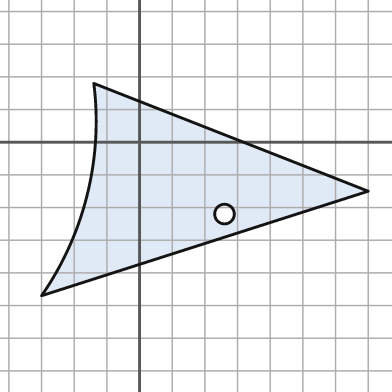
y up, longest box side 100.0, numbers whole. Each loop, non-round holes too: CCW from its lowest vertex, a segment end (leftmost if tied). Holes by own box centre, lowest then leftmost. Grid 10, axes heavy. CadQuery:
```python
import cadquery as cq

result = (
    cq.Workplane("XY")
    .moveTo(-30.0, -47.0)
    .lineTo(70.0, -15.0)
    .lineTo(-14.0, 18.0)
    .threePointArc((-16.0, -16.0), (-30.0, -47.0))
    .close()
    .moveTo(26.0, -22.0)
    .circle(3.0)
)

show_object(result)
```